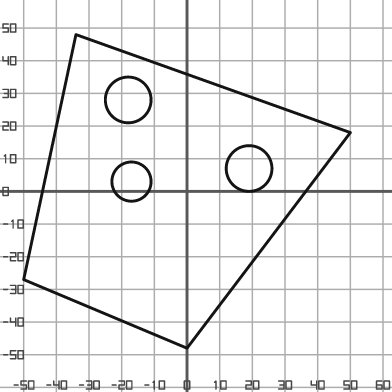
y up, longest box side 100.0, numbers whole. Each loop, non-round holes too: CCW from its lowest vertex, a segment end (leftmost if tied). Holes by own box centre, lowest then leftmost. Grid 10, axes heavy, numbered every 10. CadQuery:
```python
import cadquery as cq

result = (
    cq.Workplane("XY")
    .moveTo(0.0, -48.0)
    .lineTo(50.0, 18.0)
    .lineTo(-34.0, 48.0)
    .lineTo(-50.0, -27.0)
    .close()
    .moveTo(-17.0, 3.0)
    .circle(6.0)
    .moveTo(19.0, 7.0)
    .circle(7.0)
    .moveTo(-18.0, 28.0)
    .circle(7.0)
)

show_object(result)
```